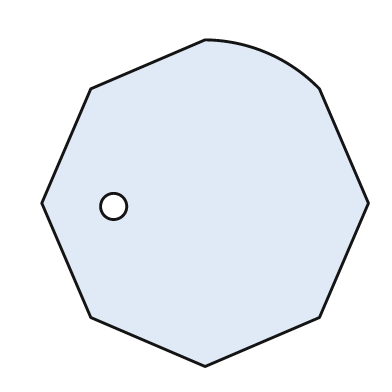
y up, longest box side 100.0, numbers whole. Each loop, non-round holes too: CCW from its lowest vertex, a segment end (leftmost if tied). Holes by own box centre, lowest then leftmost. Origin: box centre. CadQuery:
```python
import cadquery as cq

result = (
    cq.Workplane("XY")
    .moveTo(0.0, -50.0)
    .lineTo(35.0, -35.0)
    .lineTo(50.0, 0.0)
    .lineTo(35.0, 35.0)
    .threePointArc((19.0, 46.0), (0.0, 50.0))
    .lineTo(-35.0, 35.0)
    .lineTo(-50.0, 0.0)
    .lineTo(-35.0, -35.0)
    .close()
    .moveTo(-28.0, -1.0)
    .circle(4.0)
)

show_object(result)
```